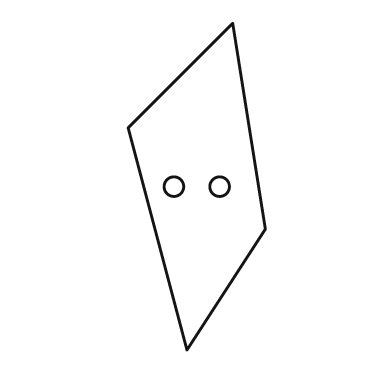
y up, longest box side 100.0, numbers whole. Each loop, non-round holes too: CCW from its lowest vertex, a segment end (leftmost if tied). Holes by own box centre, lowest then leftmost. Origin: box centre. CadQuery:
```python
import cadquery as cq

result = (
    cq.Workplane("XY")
    .moveTo(-3.0, -50.0)
    .lineTo(21.0, -13.0)
    .lineTo(11.0, 50.0)
    .lineTo(-21.0, 18.0)
    .close()
    .moveTo(-7.0, 0.0)
    .circle(3.0)
    .moveTo(7.0, 0.0)
    .circle(3.0)
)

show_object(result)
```